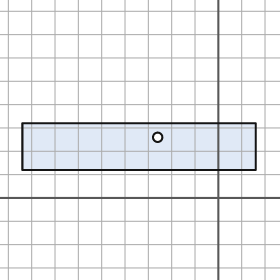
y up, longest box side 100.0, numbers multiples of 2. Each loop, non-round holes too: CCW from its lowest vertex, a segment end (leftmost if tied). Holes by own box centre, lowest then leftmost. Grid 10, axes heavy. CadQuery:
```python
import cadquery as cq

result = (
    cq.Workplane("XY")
    .moveTo(-84.0, 12.0)
    .lineTo(16.0, 12.0)
    .lineTo(16.0, 32.0)
    .lineTo(-84.0, 32.0)
    .close()
    .moveTo(-26.0, 26.0)
    .circle(2.0)
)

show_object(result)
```